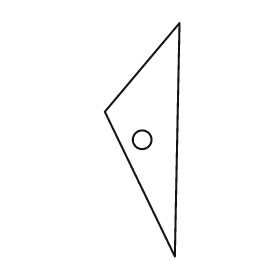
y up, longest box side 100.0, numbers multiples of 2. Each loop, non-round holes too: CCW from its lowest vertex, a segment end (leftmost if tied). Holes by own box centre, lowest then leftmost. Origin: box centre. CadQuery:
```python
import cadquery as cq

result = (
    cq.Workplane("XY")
    .moveTo(14.0, -50.0)
    .lineTo(16.0, 50.0)
    .lineTo(-16.0, 12.0)
    .close()
    .moveTo(0.0, 0.0)
    .circle(4.0)
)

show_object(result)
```